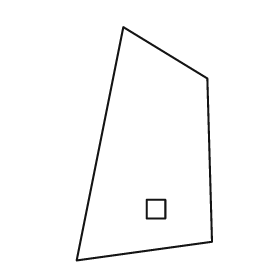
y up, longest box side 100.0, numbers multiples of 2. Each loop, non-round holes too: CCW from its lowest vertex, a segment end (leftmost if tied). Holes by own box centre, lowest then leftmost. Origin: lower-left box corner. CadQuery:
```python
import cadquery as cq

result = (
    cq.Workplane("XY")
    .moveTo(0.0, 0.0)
    .lineTo(58.0, 8.0)
    .lineTo(56.0, 78.0)
    .lineTo(20.0, 100.0)
    .close()
    .moveTo(30.0, 18.0)
    .lineTo(38.0, 18.0)
    .lineTo(38.0, 26.0)
    .lineTo(30.0, 26.0)
    .close()
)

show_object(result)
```